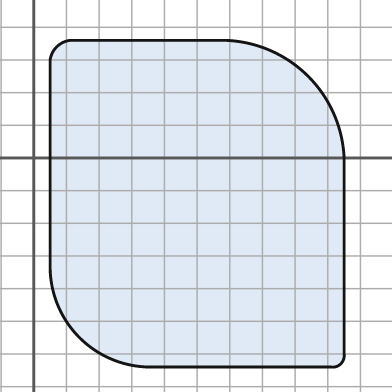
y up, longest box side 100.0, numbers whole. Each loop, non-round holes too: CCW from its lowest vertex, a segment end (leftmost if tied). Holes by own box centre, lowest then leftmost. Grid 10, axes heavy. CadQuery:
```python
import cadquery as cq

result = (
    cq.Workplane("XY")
    .moveTo(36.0, -64.0)
    .lineTo(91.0, -64.0)
    .threePointArc((94.0, -63.0), (95.0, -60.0))
    .lineTo(95.0, 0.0)
    .threePointArc((84.0, 25.0), (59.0, 36.0))
    .lineTo(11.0, 36.0)
    .threePointArc((7.0, 34.0), (5.0, 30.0))
    .lineTo(5.0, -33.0)
    .threePointArc((14.0, -55.0), (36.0, -64.0))
    .close()
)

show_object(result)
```